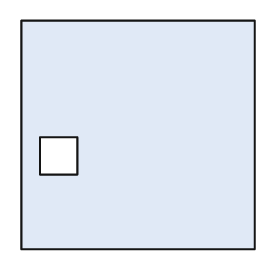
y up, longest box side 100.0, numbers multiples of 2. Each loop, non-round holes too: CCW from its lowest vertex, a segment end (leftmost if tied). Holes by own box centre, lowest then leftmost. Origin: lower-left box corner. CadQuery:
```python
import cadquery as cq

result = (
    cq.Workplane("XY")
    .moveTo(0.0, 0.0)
    .lineTo(100.0, 0.0)
    .lineTo(100.0, 98.0)
    .lineTo(0.0, 98.0)
    .close()
    .moveTo(8.0, 32.0)
    .lineTo(24.0, 32.0)
    .lineTo(24.0, 48.0)
    .lineTo(8.0, 48.0)
    .close()
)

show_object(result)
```